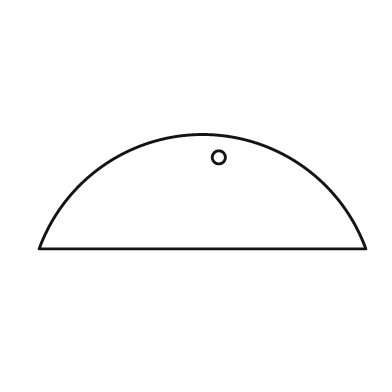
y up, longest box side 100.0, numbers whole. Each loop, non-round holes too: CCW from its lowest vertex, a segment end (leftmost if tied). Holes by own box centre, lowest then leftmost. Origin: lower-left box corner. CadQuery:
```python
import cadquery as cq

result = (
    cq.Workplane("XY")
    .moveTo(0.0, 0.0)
    .lineTo(100.0, 0.0)
    .threePointArc((50.0, 35.0), (0.0, 0.0))
    .close()
    .moveTo(55.0, 28.0)
    .circle(2.0)
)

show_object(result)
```